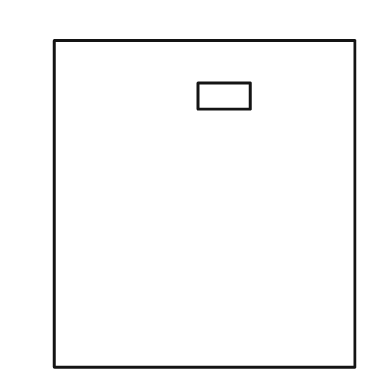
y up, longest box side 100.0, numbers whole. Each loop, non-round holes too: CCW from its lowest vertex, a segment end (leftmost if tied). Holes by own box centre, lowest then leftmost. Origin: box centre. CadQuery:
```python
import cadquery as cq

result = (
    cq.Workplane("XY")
    .moveTo(-46.0, -50.0)
    .lineTo(46.0, -50.0)
    .lineTo(46.0, 50.0)
    .lineTo(-46.0, 50.0)
    .close()
    .moveTo(-2.0, 29.0)
    .lineTo(14.0, 29.0)
    .lineTo(14.0, 37.0)
    .lineTo(-2.0, 37.0)
    .close()
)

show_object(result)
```